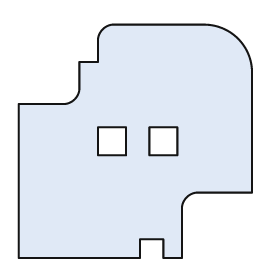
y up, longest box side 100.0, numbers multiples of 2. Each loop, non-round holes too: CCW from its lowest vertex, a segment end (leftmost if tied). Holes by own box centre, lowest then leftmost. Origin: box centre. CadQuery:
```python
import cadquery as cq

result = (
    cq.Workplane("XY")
    .moveTo(-50.0, -50.0)
    .lineTo(2.0, -50.0)
    .lineTo(2.0, -42.0)
    .lineTo(12.0, -42.0)
    .lineTo(12.0, -50.0)
    .lineTo(20.0, -50.0)
    .lineTo(20.0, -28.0)
    .threePointArc((22.0, -24.0), (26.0, -22.0))
    .lineTo(50.0, -22.0)
    .lineTo(50.0, 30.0)
    .threePointArc((44.0, 44.0), (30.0, 50.0))
    .lineTo(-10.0, 50.0)
    .threePointArc((-14.0, 48.0), (-16.0, 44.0))
    .lineTo(-16.0, 34.0)
    .lineTo(-24.0, 34.0)
    .lineTo(-24.0, 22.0)
    .threePointArc((-26.0, 18.0), (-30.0, 16.0))
    .lineTo(-50.0, 16.0)
    .close()
    .moveTo(-16.0, -6.0)
    .lineTo(-4.0, -6.0)
    .lineTo(-4.0, 6.0)
    .lineTo(-16.0, 6.0)
    .close()
    .moveTo(6.0, -6.0)
    .lineTo(18.0, -6.0)
    .lineTo(18.0, 6.0)
    .lineTo(6.0, 6.0)
    .close()
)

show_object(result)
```